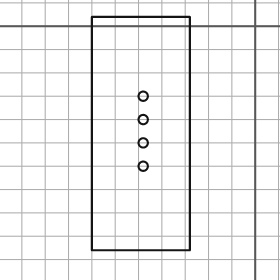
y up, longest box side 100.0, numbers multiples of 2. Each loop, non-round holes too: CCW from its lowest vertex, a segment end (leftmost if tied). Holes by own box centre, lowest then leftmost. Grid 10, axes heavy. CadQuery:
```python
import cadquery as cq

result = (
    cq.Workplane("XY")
    .moveTo(-70.0, -96.0)
    .lineTo(-28.0, -96.0)
    .lineTo(-28.0, 4.0)
    .lineTo(-70.0, 4.0)
    .close()
    .moveTo(-48.0, -60.0)
    .circle(2.0)
    .moveTo(-48.0, -50.0)
    .circle(2.0)
    .moveTo(-48.0, -40.0)
    .circle(2.0)
    .moveTo(-48.0, -30.0)
    .circle(2.0)
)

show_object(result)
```